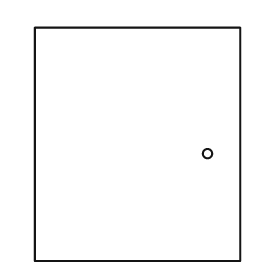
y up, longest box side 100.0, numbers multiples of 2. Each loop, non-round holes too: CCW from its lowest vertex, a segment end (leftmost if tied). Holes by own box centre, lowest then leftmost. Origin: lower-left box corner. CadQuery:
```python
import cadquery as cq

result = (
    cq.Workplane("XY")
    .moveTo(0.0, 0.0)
    .lineTo(88.0, 0.0)
    .lineTo(88.0, 100.0)
    .lineTo(0.0, 100.0)
    .close()
    .moveTo(74.0, 46.0)
    .circle(2.0)
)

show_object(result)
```